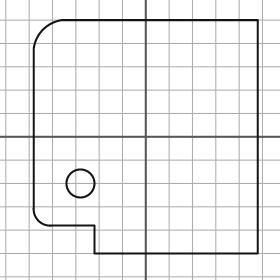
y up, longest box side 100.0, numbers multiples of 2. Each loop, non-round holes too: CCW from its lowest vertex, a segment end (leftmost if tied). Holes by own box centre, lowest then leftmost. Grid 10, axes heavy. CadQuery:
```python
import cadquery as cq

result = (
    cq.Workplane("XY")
    .moveTo(-22.0, -50.0)
    .lineTo(48.0, -50.0)
    .lineTo(48.0, 50.0)
    .lineTo(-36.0, 50.0)
    .threePointArc((-44.0, 46.0), (-48.0, 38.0))
    .lineTo(-48.0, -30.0)
    .threePointArc((-46.0, -36.0), (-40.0, -38.0))
    .lineTo(-22.0, -38.0)
    .close()
    .moveTo(-28.0, -20.0)
    .circle(6.0)
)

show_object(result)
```